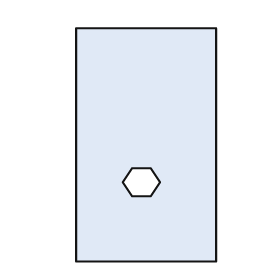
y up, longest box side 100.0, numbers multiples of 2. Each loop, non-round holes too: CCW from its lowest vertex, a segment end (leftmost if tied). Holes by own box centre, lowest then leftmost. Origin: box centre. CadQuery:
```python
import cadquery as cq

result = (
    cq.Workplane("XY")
    .moveTo(-30.0, -50.0)
    .lineTo(30.0, -50.0)
    .lineTo(30.0, 50.0)
    .lineTo(-30.0, 50.0)
    .close()
    .moveTo(-6.0, -22.0)
    .lineTo(2.0, -22.0)
    .lineTo(6.0, -16.0)
    .lineTo(2.0, -10.0)
    .lineTo(-6.0, -10.0)
    .lineTo(-10.0, -16.0)
    .close()
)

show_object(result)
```